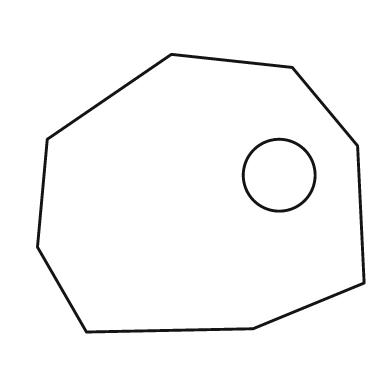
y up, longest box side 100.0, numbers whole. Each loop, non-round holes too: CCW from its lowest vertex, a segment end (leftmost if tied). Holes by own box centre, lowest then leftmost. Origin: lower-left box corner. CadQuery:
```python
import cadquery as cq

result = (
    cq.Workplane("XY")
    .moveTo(15.0, 0.0)
    .lineTo(66.0, 1.0)
    .lineTo(100.0, 15.0)
    .lineTo(98.0, 57.0)
    .lineTo(78.0, 81.0)
    .lineTo(41.0, 85.0)
    .lineTo(3.0, 59.0)
    .lineTo(0.0, 26.0)
    .close()
    .moveTo(74.0, 48.0)
    .circle(11.0)
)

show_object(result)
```